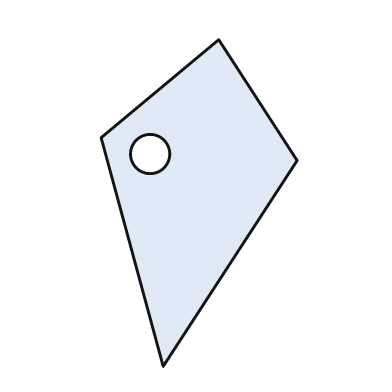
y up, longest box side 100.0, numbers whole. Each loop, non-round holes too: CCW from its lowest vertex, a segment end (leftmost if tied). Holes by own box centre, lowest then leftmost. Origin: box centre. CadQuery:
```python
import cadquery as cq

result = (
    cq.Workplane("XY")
    .moveTo(-11.0, -50.0)
    .lineTo(30.0, 13.0)
    .lineTo(6.0, 50.0)
    .lineTo(-30.0, 20.0)
    .close()
    .moveTo(-15.0, 15.0)
    .circle(6.0)
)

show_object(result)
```